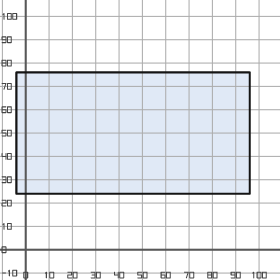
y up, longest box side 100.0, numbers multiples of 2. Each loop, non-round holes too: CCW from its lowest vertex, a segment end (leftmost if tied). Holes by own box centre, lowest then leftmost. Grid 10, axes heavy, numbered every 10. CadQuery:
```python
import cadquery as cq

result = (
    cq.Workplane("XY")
    .moveTo(-4.0, 24.0)
    .lineTo(96.0, 24.0)
    .lineTo(96.0, 76.0)
    .lineTo(-4.0, 76.0)
    .close()
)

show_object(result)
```